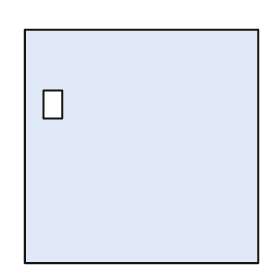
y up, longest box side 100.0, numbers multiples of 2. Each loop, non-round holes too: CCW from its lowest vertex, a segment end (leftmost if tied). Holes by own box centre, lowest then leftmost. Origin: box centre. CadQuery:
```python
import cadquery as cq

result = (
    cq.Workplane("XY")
    .moveTo(-50.0, -50.0)
    .lineTo(50.0, -50.0)
    .lineTo(50.0, 50.0)
    .lineTo(-50.0, 50.0)
    .close()
    .moveTo(-42.0, 12.0)
    .lineTo(-34.0, 12.0)
    .lineTo(-34.0, 24.0)
    .lineTo(-42.0, 24.0)
    .close()
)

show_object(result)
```